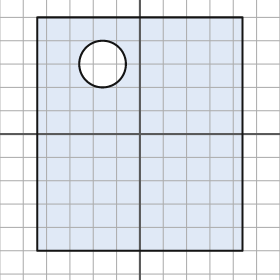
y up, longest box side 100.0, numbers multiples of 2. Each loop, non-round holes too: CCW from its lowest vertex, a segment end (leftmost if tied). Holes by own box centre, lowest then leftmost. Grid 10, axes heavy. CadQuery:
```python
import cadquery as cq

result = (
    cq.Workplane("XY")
    .moveTo(-44.0, -50.0)
    .lineTo(44.0, -50.0)
    .lineTo(44.0, 50.0)
    .lineTo(-44.0, 50.0)
    .close()
    .moveTo(-16.0, 30.0)
    .circle(10.0)
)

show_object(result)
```